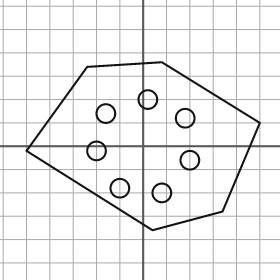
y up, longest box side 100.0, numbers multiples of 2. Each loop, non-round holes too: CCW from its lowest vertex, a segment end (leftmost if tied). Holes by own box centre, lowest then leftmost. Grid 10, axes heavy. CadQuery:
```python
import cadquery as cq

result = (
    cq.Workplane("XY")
    .moveTo(4.0, -36.0)
    .lineTo(34.0, -28.0)
    .lineTo(50.0, 10.0)
    .lineTo(8.0, 36.0)
    .lineTo(-24.0, 34.0)
    .lineTo(-50.0, -2.0)
    .close()
    .moveTo(8.0, -20.0)
    .circle(4.0)
    .moveTo(-10.0, -18.0)
    .circle(4.0)
    .moveTo(20.0, -6.0)
    .circle(4.0)
    .moveTo(-20.0, -2.0)
    .circle(4.0)
    .moveTo(18.0, 12.0)
    .circle(4.0)
    .moveTo(-16.0, 14.0)
    .circle(4.0)
    .moveTo(2.0, 20.0)
    .circle(4.0)
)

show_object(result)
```